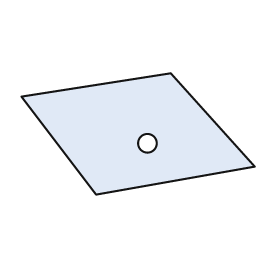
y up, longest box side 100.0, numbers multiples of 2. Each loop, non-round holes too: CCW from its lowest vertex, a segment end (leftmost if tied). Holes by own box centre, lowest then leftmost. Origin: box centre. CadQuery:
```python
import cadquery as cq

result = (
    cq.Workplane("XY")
    .moveTo(-18.0, -26.0)
    .lineTo(50.0, -14.0)
    .lineTo(14.0, 26.0)
    .lineTo(-50.0, 16.0)
    .close()
    .moveTo(4.0, -4.0)
    .circle(4.0)
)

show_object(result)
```